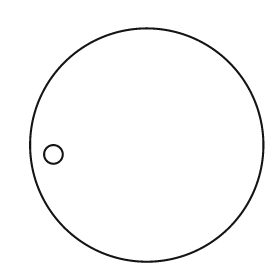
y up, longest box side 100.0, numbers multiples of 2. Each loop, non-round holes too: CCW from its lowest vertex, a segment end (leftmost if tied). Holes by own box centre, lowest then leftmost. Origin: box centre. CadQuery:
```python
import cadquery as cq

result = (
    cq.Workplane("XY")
    .moveTo(0.0, 0.0)
    .circle(50.0)
    .moveTo(-40.0, -4.0)
    .circle(4.0)
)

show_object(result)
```